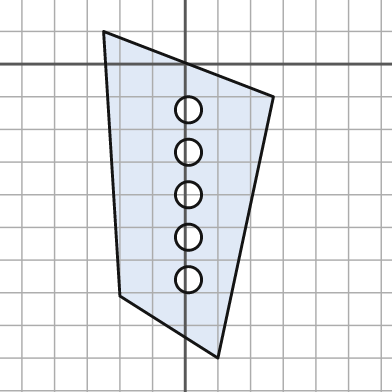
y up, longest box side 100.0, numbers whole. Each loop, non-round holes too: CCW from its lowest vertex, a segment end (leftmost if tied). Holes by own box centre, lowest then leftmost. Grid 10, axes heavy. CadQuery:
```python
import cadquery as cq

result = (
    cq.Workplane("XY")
    .moveTo(10.0, -90.0)
    .lineTo(27.0, -10.0)
    .lineTo(-25.0, 10.0)
    .lineTo(-20.0, -71.0)
    .close()
    .moveTo(1.0, -66.0)
    .circle(4.0)
    .moveTo(1.0, -53.0)
    .circle(4.0)
    .moveTo(1.0, -40.0)
    .circle(4.0)
    .moveTo(1.0, -27.0)
    .circle(4.0)
    .moveTo(1.0, -14.0)
    .circle(4.0)
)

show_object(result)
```